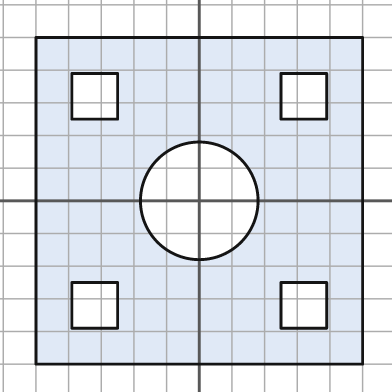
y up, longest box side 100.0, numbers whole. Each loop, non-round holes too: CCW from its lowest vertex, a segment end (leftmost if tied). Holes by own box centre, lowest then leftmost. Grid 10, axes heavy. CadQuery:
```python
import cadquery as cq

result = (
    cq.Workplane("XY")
    .moveTo(-50.0, -50.0)
    .lineTo(50.0, -50.0)
    .lineTo(50.0, 50.0)
    .lineTo(-50.0, 50.0)
    .close()
    .moveTo(-39.0, -39.0)
    .lineTo(-25.0, -39.0)
    .lineTo(-25.0, -25.0)
    .lineTo(-39.0, -25.0)
    .close()
    .moveTo(25.0, -39.0)
    .lineTo(39.0, -39.0)
    .lineTo(39.0, -25.0)
    .lineTo(25.0, -25.0)
    .close()
    .moveTo(0.0, 0.0)
    .circle(18.0)
    .moveTo(-39.0, 25.0)
    .lineTo(-25.0, 25.0)
    .lineTo(-25.0, 39.0)
    .lineTo(-39.0, 39.0)
    .close()
    .moveTo(25.0, 25.0)
    .lineTo(39.0, 25.0)
    .lineTo(39.0, 39.0)
    .lineTo(25.0, 39.0)
    .close()
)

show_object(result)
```